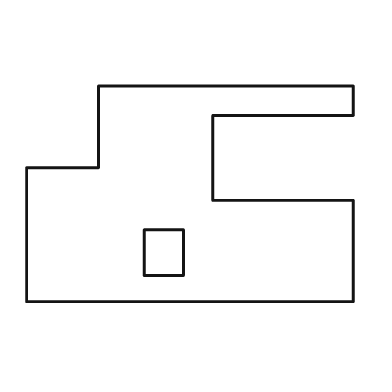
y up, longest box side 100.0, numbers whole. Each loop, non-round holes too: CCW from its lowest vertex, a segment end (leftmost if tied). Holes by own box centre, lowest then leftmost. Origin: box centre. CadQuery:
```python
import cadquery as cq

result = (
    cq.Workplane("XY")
    .moveTo(-50.0, -33.0)
    .lineTo(50.0, -33.0)
    .lineTo(50.0, -2.0)
    .lineTo(7.0, -2.0)
    .lineTo(7.0, 24.0)
    .lineTo(50.0, 24.0)
    .lineTo(50.0, 33.0)
    .lineTo(-28.0, 33.0)
    .lineTo(-28.0, 8.0)
    .lineTo(-50.0, 8.0)
    .close()
    .moveTo(-14.0, -25.0)
    .lineTo(-2.0, -25.0)
    .lineTo(-2.0, -11.0)
    .lineTo(-14.0, -11.0)
    .close()
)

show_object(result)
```